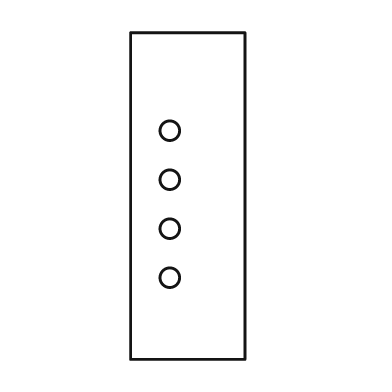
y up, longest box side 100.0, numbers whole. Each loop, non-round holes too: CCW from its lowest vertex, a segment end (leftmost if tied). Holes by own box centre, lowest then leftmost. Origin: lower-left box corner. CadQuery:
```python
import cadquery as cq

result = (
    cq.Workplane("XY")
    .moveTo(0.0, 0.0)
    .lineTo(35.0, 0.0)
    .lineTo(35.0, 100.0)
    .lineTo(0.0, 100.0)
    .close()
    .moveTo(12.0, 25.0)
    .circle(3.0)
    .moveTo(12.0, 40.0)
    .circle(3.0)
    .moveTo(12.0, 55.0)
    .circle(3.0)
    .moveTo(12.0, 70.0)
    .circle(3.0)
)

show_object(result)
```